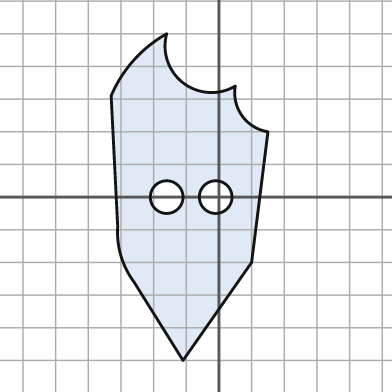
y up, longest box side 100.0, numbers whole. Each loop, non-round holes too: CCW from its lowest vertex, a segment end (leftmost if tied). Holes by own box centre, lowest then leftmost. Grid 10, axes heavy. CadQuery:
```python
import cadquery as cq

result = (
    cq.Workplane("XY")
    .moveTo(-11.0, -50.0)
    .lineTo(10.0, -20.0)
    .lineTo(15.0, 20.0)
    .threePointArc((7.0, 25.0), (5.0, 34.0))
    .threePointArc((-11.0, 35.0), (-16.0, 50.0))
    .threePointArc((-26.0, 42.0), (-33.0, 31.0))
    .lineTo(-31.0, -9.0)
    .threePointArc((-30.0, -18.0), (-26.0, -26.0))
    .close()
    .moveTo(-16.0, 0.0)
    .circle(5.0)
    .moveTo(-1.0, 0.0)
    .circle(5.0)
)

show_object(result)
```